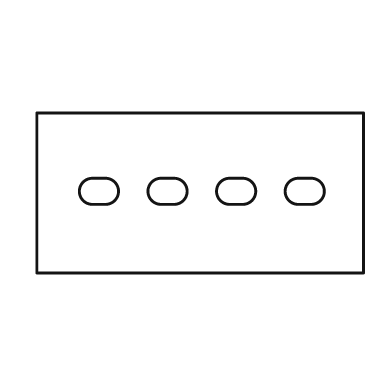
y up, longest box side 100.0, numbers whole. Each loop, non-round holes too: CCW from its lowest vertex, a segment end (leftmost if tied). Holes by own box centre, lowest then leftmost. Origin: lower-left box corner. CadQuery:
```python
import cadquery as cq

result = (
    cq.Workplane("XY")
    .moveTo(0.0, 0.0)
    .lineTo(100.0, 0.0)
    .lineTo(100.0, 49.0)
    .lineTo(0.0, 49.0)
    .close()
    .moveTo(17.0, 21.0)
    .lineTo(21.0, 21.0)
    .threePointArc((25.0, 25.0), (21.0, 29.0))
    .lineTo(17.0, 29.0)
    .threePointArc((13.0, 25.0), (17.0, 21.0))
    .close()
    .moveTo(38.0, 21.0)
    .lineTo(42.0, 21.0)
    .threePointArc((46.0, 25.0), (42.0, 29.0))
    .lineTo(38.0, 29.0)
    .threePointArc((34.0, 25.0), (38.0, 21.0))
    .close()
    .moveTo(59.0, 21.0)
    .lineTo(63.0, 21.0)
    .threePointArc((67.0, 25.0), (63.0, 29.0))
    .lineTo(59.0, 29.0)
    .threePointArc((55.0, 25.0), (59.0, 21.0))
    .close()
    .moveTo(80.0, 21.0)
    .lineTo(84.0, 21.0)
    .threePointArc((88.0, 25.0), (84.0, 29.0))
    .lineTo(80.0, 29.0)
    .threePointArc((76.0, 25.0), (80.0, 21.0))
    .close()
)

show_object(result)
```